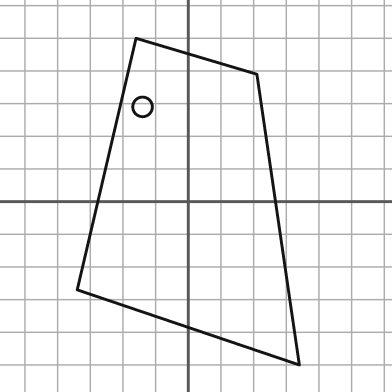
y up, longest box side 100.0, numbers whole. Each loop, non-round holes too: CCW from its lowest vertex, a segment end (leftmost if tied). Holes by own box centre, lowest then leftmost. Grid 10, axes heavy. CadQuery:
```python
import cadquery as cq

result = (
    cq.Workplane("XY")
    .moveTo(34.0, -50.0)
    .lineTo(21.0, 39.0)
    .lineTo(-16.0, 50.0)
    .lineTo(-34.0, -27.0)
    .close()
    .moveTo(-14.0, 29.0)
    .circle(3.0)
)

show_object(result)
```